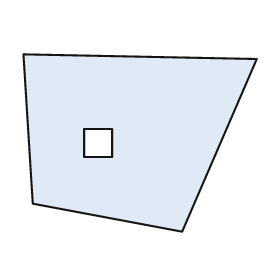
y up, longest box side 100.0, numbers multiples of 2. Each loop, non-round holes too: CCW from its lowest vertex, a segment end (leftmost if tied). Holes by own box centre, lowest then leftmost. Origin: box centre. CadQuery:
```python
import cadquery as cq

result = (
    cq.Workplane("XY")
    .moveTo(18.0, -38.0)
    .lineTo(50.0, 36.0)
    .lineTo(-50.0, 38.0)
    .lineTo(-46.0, -26.0)
    .close()
    .moveTo(-24.0, -6.0)
    .lineTo(-12.0, -6.0)
    .lineTo(-12.0, 6.0)
    .lineTo(-24.0, 6.0)
    .close()
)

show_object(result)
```